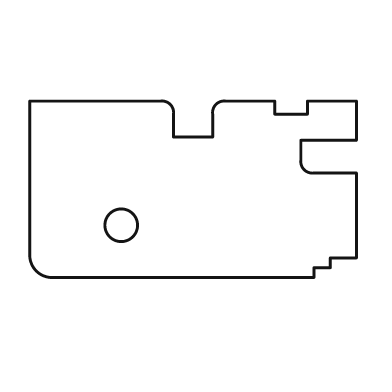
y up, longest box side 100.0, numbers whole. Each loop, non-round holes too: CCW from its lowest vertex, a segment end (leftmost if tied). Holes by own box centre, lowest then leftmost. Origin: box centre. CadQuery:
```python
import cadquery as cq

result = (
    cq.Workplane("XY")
    .moveTo(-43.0, -27.0)
    .lineTo(37.0, -27.0)
    .lineTo(37.0, -24.0)
    .lineTo(42.0, -24.0)
    .lineTo(42.0, -21.0)
    .lineTo(50.0, -21.0)
    .lineTo(50.0, 5.0)
    .lineTo(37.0, 5.0)
    .threePointArc((34.0, 6.0), (33.0, 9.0))
    .lineTo(33.0, 15.0)
    .lineTo(50.0, 15.0)
    .lineTo(50.0, 27.0)
    .lineTo(35.0, 27.0)
    .lineTo(35.0, 23.0)
    .lineTo(25.0, 23.0)
    .lineTo(25.0, 27.0)
    .lineTo(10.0, 27.0)
    .threePointArc((7.0, 26.0), (6.0, 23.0))
    .lineTo(6.0, 16.0)
    .lineTo(-6.0, 16.0)
    .lineTo(-6.0, 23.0)
    .threePointArc((-7.0, 26.0), (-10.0, 27.0))
    .lineTo(-50.0, 27.0)
    .lineTo(-50.0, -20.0)
    .threePointArc((-48.0, -25.0), (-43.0, -27.0))
    .close()
    .moveTo(-22.0, -11.0)
    .circle(5.0)
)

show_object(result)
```